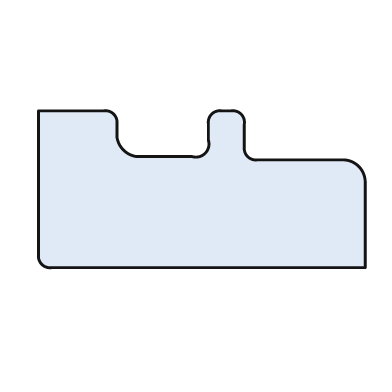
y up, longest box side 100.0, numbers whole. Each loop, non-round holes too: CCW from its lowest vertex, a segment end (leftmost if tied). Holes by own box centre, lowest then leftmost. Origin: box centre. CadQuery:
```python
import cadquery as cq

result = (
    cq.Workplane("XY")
    .moveTo(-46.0, -24.0)
    .lineTo(50.0, -24.0)
    .lineTo(50.0, 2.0)
    .threePointArc((48.0, 7.0), (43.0, 9.0))
    .lineTo(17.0, 9.0)
    .threePointArc((14.0, 10.0), (13.0, 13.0))
    .lineTo(13.0, 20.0)
    .threePointArc((12.0, 23.0), (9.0, 24.0))
    .lineTo(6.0, 24.0)
    .threePointArc((3.0, 23.0), (2.0, 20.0))
    .lineTo(2.0, 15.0)
    .threePointArc((1.0, 11.0), (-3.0, 10.0))
    .lineTo(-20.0, 10.0)
    .threePointArc((-24.0, 12.0), (-26.0, 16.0))
    .lineTo(-26.0, 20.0)
    .threePointArc((-27.0, 23.0), (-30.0, 24.0))
    .lineTo(-50.0, 24.0)
    .lineTo(-50.0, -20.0)
    .threePointArc((-49.0, -23.0), (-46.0, -24.0))
    .close()
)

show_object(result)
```